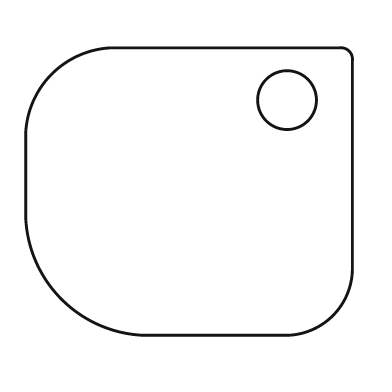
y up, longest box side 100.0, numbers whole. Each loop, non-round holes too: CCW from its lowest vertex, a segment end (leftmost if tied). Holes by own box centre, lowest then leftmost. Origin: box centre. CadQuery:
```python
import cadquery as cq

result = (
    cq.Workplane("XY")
    .moveTo(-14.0, -44.0)
    .lineTo(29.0, -44.0)
    .threePointArc((44.0, -38.0), (50.0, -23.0))
    .lineTo(50.0, 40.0)
    .threePointArc((49.0, 43.0), (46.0, 44.0))
    .lineTo(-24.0, 44.0)
    .threePointArc((-42.0, 36.0), (-50.0, 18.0))
    .lineTo(-50.0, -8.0)
    .threePointArc((-39.0, -33.0), (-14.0, -44.0))
    .close()
    .moveTo(30.0, 28.0)
    .circle(9.0)
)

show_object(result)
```